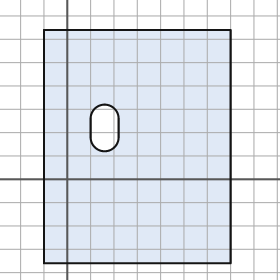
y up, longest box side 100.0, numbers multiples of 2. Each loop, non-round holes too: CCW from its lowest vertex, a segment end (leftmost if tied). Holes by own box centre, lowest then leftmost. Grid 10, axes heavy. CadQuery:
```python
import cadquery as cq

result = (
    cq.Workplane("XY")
    .moveTo(-10.0, -36.0)
    .lineTo(70.0, -36.0)
    .lineTo(70.0, 64.0)
    .lineTo(-10.0, 64.0)
    .close()
    .moveTo(10.0, 18.0)
    .threePointArc((16.0, 12.0), (22.0, 18.0))
    .lineTo(22.0, 26.0)
    .threePointArc((16.0, 32.0), (10.0, 26.0))
    .close()
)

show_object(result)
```